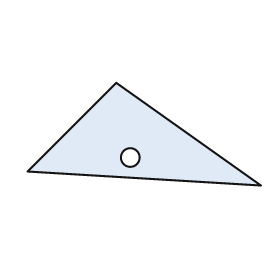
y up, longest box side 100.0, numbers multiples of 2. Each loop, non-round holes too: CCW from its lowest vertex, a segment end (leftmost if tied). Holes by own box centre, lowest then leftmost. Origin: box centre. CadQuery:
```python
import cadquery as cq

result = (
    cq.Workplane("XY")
    .moveTo(50.0, -22.0)
    .lineTo(-12.0, 22.0)
    .lineTo(-50.0, -16.0)
    .close()
    .moveTo(-6.0, -10.0)
    .circle(4.0)
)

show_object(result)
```